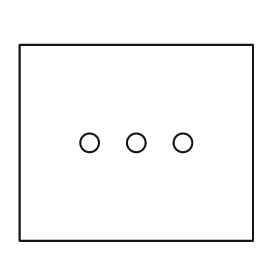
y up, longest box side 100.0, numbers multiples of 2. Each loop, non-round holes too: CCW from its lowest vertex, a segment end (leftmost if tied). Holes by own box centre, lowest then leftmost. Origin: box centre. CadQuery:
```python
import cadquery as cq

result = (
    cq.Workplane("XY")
    .moveTo(-50.0, -42.0)
    .lineTo(50.0, -42.0)
    .lineTo(50.0, 42.0)
    .lineTo(-50.0, 42.0)
    .close()
    .moveTo(-20.0, 0.0)
    .circle(4.0)
    .moveTo(0.0, 0.0)
    .circle(4.0)
    .moveTo(20.0, 0.0)
    .circle(4.0)
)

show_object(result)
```